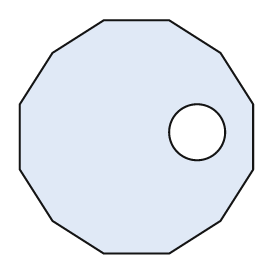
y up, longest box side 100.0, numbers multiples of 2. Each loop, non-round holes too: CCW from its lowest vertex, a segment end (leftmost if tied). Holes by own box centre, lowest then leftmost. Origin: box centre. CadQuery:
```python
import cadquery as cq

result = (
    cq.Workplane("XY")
    .moveTo(-14.0, -50.0)
    .lineTo(14.0, -50.0)
    .lineTo(36.0, -36.0)
    .lineTo(50.0, -14.0)
    .lineTo(50.0, 14.0)
    .lineTo(36.0, 36.0)
    .lineTo(14.0, 50.0)
    .lineTo(-14.0, 50.0)
    .lineTo(-36.0, 36.0)
    .lineTo(-50.0, 14.0)
    .lineTo(-50.0, -14.0)
    .lineTo(-36.0, -36.0)
    .close()
    .moveTo(26.0, 2.0)
    .circle(12.0)
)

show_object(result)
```